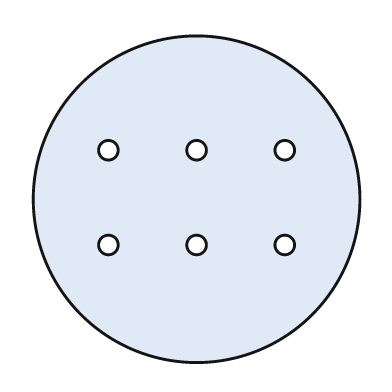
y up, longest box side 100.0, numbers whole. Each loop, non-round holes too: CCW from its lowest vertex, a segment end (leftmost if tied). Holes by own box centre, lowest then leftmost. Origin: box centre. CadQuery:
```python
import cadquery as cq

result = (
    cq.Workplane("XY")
    .moveTo(0.0, 0.0)
    .circle(50.0)
    .moveTo(-27.0, -14.0)
    .circle(3.0)
    .moveTo(0.0, -14.0)
    .circle(3.0)
    .moveTo(27.0, -14.0)
    .circle(3.0)
    .moveTo(-27.0, 15.0)
    .circle(3.0)
    .moveTo(0.0, 15.0)
    .circle(3.0)
    .moveTo(27.0, 15.0)
    .circle(3.0)
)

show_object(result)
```